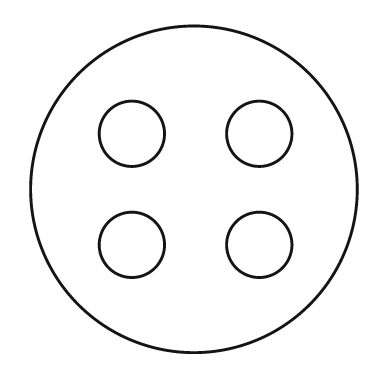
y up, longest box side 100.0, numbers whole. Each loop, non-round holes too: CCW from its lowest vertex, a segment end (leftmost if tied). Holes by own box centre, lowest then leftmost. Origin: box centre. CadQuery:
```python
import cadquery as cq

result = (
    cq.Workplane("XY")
    .moveTo(0.0, 0.0)
    .circle(50.0)
    .moveTo(-19.0, -17.0)
    .circle(10.0)
    .moveTo(20.0, -17.0)
    .circle(10.0)
    .moveTo(-19.0, 17.0)
    .circle(10.0)
    .moveTo(20.0, 17.0)
    .circle(10.0)
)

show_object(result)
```